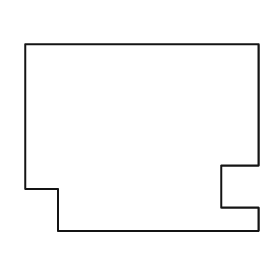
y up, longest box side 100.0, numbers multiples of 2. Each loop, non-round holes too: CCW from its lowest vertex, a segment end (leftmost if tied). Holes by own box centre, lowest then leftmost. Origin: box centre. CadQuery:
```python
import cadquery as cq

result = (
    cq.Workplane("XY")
    .moveTo(-36.0, -40.0)
    .lineTo(50.0, -40.0)
    .lineTo(50.0, -30.0)
    .lineTo(34.0, -30.0)
    .lineTo(34.0, -12.0)
    .lineTo(50.0, -12.0)
    .lineTo(50.0, 40.0)
    .lineTo(-50.0, 40.0)
    .lineTo(-50.0, -22.0)
    .lineTo(-36.0, -22.0)
    .close()
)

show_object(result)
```